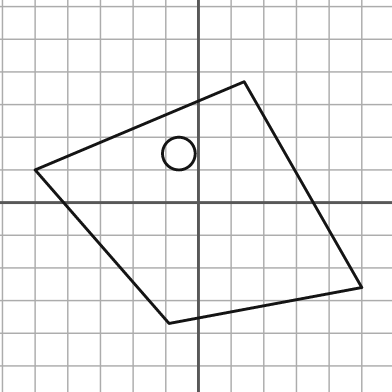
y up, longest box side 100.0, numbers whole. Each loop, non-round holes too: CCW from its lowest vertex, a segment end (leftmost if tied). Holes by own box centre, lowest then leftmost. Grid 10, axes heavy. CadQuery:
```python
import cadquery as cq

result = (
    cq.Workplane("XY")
    .moveTo(-9.0, -37.0)
    .lineTo(50.0, -26.0)
    .lineTo(14.0, 37.0)
    .lineTo(-50.0, 10.0)
    .close()
    .moveTo(-6.0, 15.0)
    .circle(5.0)
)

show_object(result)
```